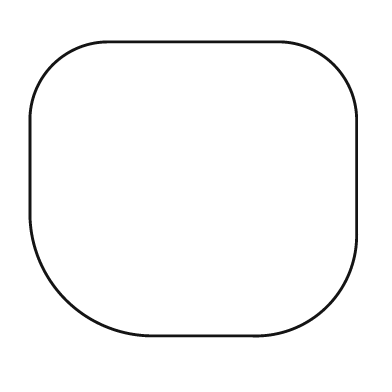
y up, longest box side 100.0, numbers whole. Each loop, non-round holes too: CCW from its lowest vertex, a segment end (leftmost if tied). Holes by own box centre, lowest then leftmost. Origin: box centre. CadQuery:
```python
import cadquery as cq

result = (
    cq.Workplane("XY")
    .moveTo(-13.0, -45.0)
    .lineTo(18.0, -45.0)
    .threePointArc((41.0, -36.0), (50.0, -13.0))
    .lineTo(50.0, 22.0)
    .threePointArc((43.0, 38.0), (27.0, 45.0))
    .lineTo(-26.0, 45.0)
    .threePointArc((-43.0, 38.0), (-50.0, 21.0))
    .lineTo(-50.0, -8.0)
    .threePointArc((-39.0, -34.0), (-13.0, -45.0))
    .close()
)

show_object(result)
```